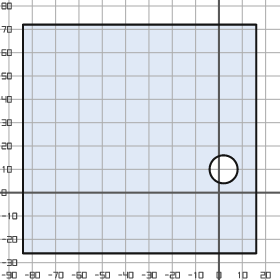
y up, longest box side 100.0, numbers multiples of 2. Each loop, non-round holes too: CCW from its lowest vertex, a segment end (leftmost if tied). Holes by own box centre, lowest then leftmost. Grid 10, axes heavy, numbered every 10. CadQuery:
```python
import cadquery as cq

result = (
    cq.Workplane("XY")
    .moveTo(-84.0, -26.0)
    .lineTo(16.0, -26.0)
    .lineTo(16.0, 72.0)
    .lineTo(-84.0, 72.0)
    .close()
    .moveTo(2.0, 10.0)
    .circle(6.0)
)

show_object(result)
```